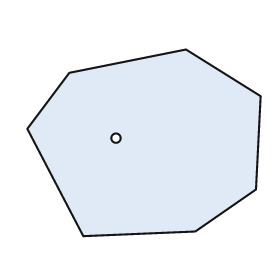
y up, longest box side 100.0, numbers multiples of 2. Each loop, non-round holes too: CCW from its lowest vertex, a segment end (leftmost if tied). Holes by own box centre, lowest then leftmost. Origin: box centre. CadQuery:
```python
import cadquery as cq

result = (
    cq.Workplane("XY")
    .moveTo(-26.0, -40.0)
    .lineTo(22.0, -38.0)
    .lineTo(48.0, -20.0)
    .lineTo(50.0, 20.0)
    .lineTo(18.0, 40.0)
    .lineTo(-32.0, 30.0)
    .lineTo(-50.0, 6.0)
    .close()
    .moveTo(-12.0, 2.0)
    .circle(2.0)
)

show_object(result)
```